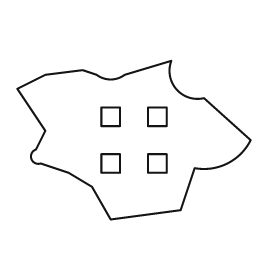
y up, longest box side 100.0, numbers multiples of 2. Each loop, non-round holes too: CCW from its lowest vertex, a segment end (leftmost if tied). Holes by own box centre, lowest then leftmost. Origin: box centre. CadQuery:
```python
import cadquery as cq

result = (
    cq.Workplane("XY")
    .moveTo(-10.0, -34.0)
    .lineTo(20.0, -30.0)
    .lineTo(26.0, -12.0)
    .threePointArc((40.0, -10.0), (50.0, 0.0))
    .lineTo(30.0, 18.0)
    .threePointArc((18.0, 22.0), (16.0, 34.0))
    .lineTo(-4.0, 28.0)
    .threePointArc((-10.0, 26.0), (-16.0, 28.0))
    .lineTo(-22.0, 30.0)
    .lineTo(-38.0, 28.0)
    .lineTo(-50.0, 22.0)
    .lineTo(-38.0, 4.0)
    .lineTo(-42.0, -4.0)
    .threePointArc((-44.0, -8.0), (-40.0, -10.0))
    .lineTo(-28.0, -14.0)
    .lineTo(-18.0, -20.0)
    .close()
    .moveTo(-14.0, -14.0)
    .lineTo(-6.0, -14.0)
    .lineTo(-6.0, -6.0)
    .lineTo(-14.0, -6.0)
    .close()
    .moveTo(6.0, -14.0)
    .lineTo(14.0, -14.0)
    .lineTo(14.0, -6.0)
    .lineTo(6.0, -6.0)
    .close()
    .moveTo(-14.0, 6.0)
    .lineTo(-6.0, 6.0)
    .lineTo(-6.0, 14.0)
    .lineTo(-14.0, 14.0)
    .close()
    .moveTo(6.0, 6.0)
    .lineTo(14.0, 6.0)
    .lineTo(14.0, 14.0)
    .lineTo(6.0, 14.0)
    .close()
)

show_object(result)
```